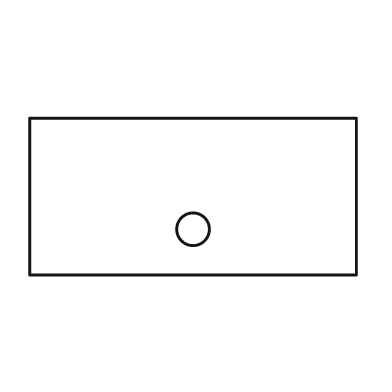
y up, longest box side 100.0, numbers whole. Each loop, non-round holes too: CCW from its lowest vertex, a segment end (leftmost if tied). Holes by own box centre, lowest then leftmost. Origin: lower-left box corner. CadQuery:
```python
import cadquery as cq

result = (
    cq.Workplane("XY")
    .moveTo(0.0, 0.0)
    .lineTo(100.0, 0.0)
    .lineTo(100.0, 48.0)
    .lineTo(0.0, 48.0)
    .close()
    .moveTo(50.0, 14.0)
    .circle(5.0)
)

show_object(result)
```